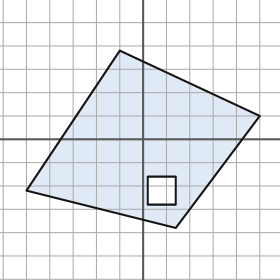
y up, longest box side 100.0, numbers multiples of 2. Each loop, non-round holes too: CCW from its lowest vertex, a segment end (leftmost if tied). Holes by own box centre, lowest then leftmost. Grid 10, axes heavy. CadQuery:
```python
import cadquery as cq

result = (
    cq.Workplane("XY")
    .moveTo(14.0, -38.0)
    .lineTo(50.0, 10.0)
    .lineTo(-10.0, 38.0)
    .lineTo(-50.0, -22.0)
    .close()
    .moveTo(2.0, -28.0)
    .lineTo(14.0, -28.0)
    .lineTo(14.0, -16.0)
    .lineTo(2.0, -16.0)
    .close()
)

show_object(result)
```